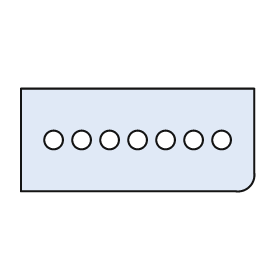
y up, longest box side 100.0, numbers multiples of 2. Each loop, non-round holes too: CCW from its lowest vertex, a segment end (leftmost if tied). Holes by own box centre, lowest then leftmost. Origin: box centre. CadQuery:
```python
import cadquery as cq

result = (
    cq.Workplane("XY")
    .moveTo(-50.0, -22.0)
    .lineTo(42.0, -22.0)
    .threePointArc((48.0, -20.0), (50.0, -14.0))
    .lineTo(50.0, 22.0)
    .lineTo(-50.0, 22.0)
    .close()
    .moveTo(-36.0, 0.0)
    .circle(4.0)
    .moveTo(-24.0, 0.0)
    .circle(4.0)
    .moveTo(-12.0, 0.0)
    .circle(4.0)
    .moveTo(0.0, 0.0)
    .circle(4.0)
    .moveTo(12.0, 0.0)
    .circle(4.0)
    .moveTo(24.0, 0.0)
    .circle(4.0)
    .moveTo(36.0, 0.0)
    .circle(4.0)
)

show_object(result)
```